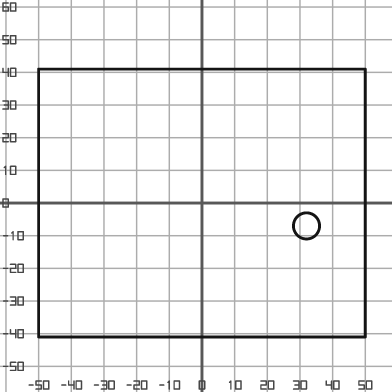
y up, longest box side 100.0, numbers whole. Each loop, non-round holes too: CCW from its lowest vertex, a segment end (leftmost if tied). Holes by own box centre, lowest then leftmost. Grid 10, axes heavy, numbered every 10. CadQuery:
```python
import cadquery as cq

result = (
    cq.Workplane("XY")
    .moveTo(-50.0, -41.0)
    .lineTo(50.0, -41.0)
    .lineTo(50.0, 41.0)
    .lineTo(-50.0, 41.0)
    .close()
    .moveTo(32.0, -7.0)
    .circle(4.0)
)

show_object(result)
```